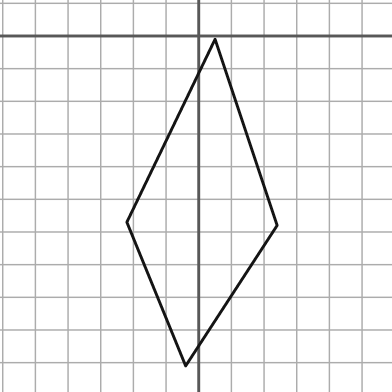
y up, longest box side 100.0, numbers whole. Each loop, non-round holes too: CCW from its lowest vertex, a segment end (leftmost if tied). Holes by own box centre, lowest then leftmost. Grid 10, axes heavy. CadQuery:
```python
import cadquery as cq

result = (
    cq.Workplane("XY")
    .moveTo(-4.0, -101.0)
    .lineTo(24.0, -58.0)
    .lineTo(5.0, -1.0)
    .lineTo(-22.0, -57.0)
    .close()
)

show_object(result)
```